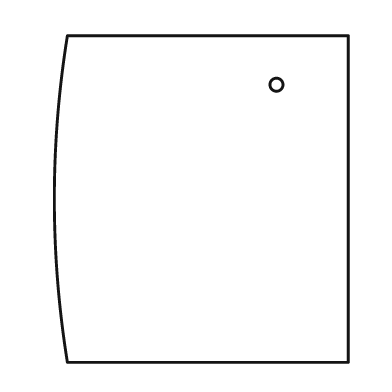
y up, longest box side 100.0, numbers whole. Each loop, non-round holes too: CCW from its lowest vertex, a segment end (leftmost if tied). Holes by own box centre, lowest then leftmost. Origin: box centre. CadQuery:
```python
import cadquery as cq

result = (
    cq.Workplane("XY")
    .moveTo(-41.0, -50.0)
    .lineTo(45.0, -50.0)
    .lineTo(45.0, 50.0)
    .lineTo(-41.0, 50.0)
    .threePointArc((-45.0, 0.0), (-41.0, -50.0))
    .close()
    .moveTo(23.0, 35.0)
    .circle(2.0)
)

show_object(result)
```